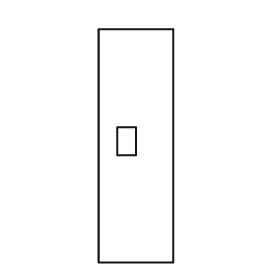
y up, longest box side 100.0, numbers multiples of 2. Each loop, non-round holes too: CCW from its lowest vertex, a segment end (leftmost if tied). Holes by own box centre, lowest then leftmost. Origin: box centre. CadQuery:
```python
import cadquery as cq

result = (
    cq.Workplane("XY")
    .moveTo(-16.0, -50.0)
    .lineTo(16.0, -50.0)
    .lineTo(16.0, 50.0)
    .lineTo(-16.0, 50.0)
    .close()
    .moveTo(-8.0, -4.0)
    .lineTo(0.0, -4.0)
    .lineTo(0.0, 8.0)
    .lineTo(-8.0, 8.0)
    .close()
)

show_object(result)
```